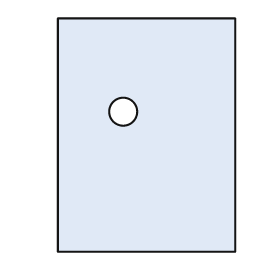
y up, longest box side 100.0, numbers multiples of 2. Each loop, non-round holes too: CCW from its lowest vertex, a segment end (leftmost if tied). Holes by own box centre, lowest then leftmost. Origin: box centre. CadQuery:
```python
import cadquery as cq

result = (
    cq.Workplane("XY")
    .moveTo(-38.0, -50.0)
    .lineTo(38.0, -50.0)
    .lineTo(38.0, 50.0)
    .lineTo(-38.0, 50.0)
    .close()
    .moveTo(-10.0, 10.0)
    .circle(6.0)
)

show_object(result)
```